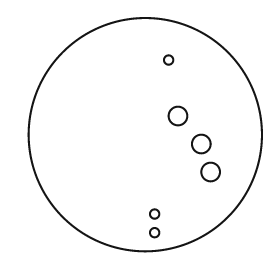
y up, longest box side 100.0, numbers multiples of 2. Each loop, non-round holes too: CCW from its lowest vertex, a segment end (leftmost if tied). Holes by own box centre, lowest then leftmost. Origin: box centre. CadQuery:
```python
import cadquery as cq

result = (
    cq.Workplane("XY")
    .moveTo(0.0, 0.0)
    .circle(50.0)
    .moveTo(4.0, -42.0)
    .circle(2.0)
    .moveTo(4.0, -34.0)
    .circle(2.0)
    .moveTo(28.0, -16.0)
    .circle(4.0)
    .moveTo(24.0, -4.0)
    .circle(4.0)
    .moveTo(14.0, 8.0)
    .circle(4.0)
    .moveTo(10.0, 32.0)
    .circle(2.0)
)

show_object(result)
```